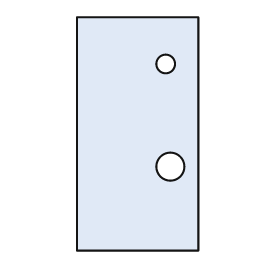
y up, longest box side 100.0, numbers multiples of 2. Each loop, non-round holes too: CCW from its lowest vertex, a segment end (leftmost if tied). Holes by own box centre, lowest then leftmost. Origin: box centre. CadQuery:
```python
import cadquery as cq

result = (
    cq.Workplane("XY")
    .moveTo(-26.0, -50.0)
    .lineTo(26.0, -50.0)
    .lineTo(26.0, 50.0)
    .lineTo(-26.0, 50.0)
    .close()
    .moveTo(14.0, -14.0)
    .circle(6.0)
    .moveTo(12.0, 30.0)
    .circle(4.0)
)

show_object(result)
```